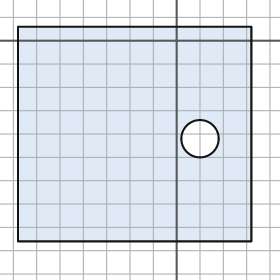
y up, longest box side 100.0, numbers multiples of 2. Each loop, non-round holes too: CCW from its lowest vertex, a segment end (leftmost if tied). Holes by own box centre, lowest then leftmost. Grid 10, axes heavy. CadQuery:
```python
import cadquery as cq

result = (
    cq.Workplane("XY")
    .moveTo(-68.0, -86.0)
    .lineTo(32.0, -86.0)
    .lineTo(32.0, 6.0)
    .lineTo(-68.0, 6.0)
    .close()
    .moveTo(10.0, -42.0)
    .circle(8.0)
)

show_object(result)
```